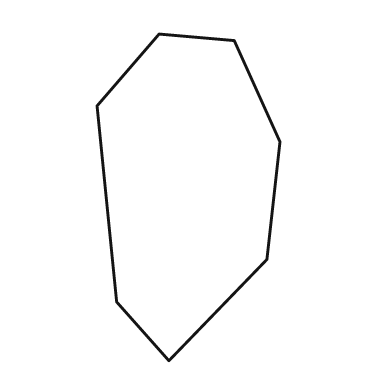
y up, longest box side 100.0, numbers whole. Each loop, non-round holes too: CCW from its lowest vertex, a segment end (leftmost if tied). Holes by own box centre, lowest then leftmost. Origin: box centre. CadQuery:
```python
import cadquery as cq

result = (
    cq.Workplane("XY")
    .moveTo(-6.0, -50.0)
    .lineTo(24.0, -19.0)
    .lineTo(28.0, 17.0)
    .lineTo(14.0, 48.0)
    .lineTo(-9.0, 50.0)
    .lineTo(-28.0, 28.0)
    .lineTo(-22.0, -32.0)
    .close()
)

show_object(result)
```